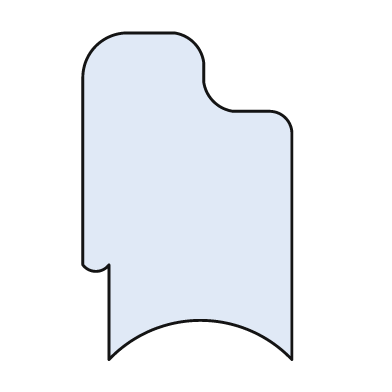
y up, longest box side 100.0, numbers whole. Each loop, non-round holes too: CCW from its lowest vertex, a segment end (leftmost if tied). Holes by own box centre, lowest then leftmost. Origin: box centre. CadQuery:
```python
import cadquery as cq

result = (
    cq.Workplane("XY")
    .moveTo(-24.0, -50.0)
    .threePointArc((4.0, -38.0), (32.0, -50.0))
    .lineTo(32.0, 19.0)
    .threePointArc((30.0, 24.0), (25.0, 26.0))
    .lineTo(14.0, 26.0)
    .threePointArc((8.0, 29.0), (5.0, 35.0))
    .lineTo(5.0, 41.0)
    .threePointArc((2.0, 47.0), (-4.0, 50.0))
    .lineTo(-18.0, 50.0)
    .threePointArc((-28.0, 46.0), (-32.0, 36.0))
    .lineTo(-32.0, -21.0)
    .threePointArc((-28.0, -23.0), (-24.0, -21.0))
    .close()
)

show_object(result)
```